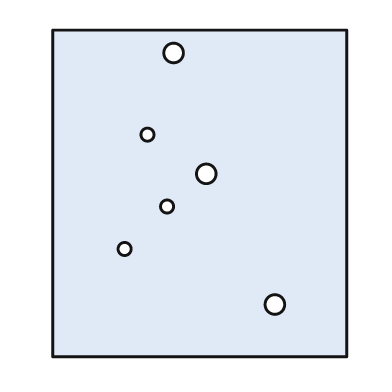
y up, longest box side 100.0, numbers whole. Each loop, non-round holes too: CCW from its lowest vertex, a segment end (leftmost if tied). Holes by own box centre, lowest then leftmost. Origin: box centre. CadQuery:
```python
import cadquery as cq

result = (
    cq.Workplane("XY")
    .moveTo(-45.0, -50.0)
    .lineTo(45.0, -50.0)
    .lineTo(45.0, 50.0)
    .lineTo(-45.0, 50.0)
    .close()
    .moveTo(23.0, -34.0)
    .circle(3.0)
    .moveTo(-23.0, -17.0)
    .circle(2.0)
    .moveTo(-10.0, -4.0)
    .circle(2.0)
    .moveTo(2.0, 6.0)
    .circle(3.0)
    .moveTo(-16.0, 18.0)
    .circle(2.0)
    .moveTo(-8.0, 43.0)
    .circle(3.0)
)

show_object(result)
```